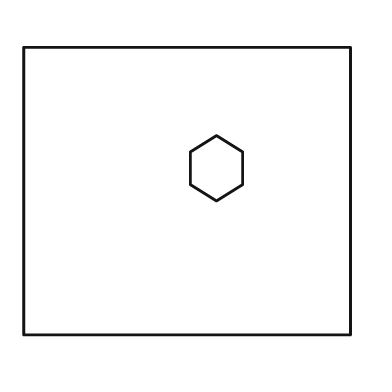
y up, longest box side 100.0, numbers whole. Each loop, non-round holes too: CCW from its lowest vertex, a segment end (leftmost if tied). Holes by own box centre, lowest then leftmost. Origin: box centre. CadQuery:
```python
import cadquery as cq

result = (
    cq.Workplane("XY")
    .moveTo(-50.0, -44.0)
    .lineTo(50.0, -44.0)
    .lineTo(50.0, 44.0)
    .lineTo(-50.0, 44.0)
    .close()
    .moveTo(9.0, -3.0)
    .lineTo(17.0, 2.0)
    .lineTo(17.0, 12.0)
    .lineTo(9.0, 17.0)
    .lineTo(1.0, 12.0)
    .lineTo(1.0, 2.0)
    .close()
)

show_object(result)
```